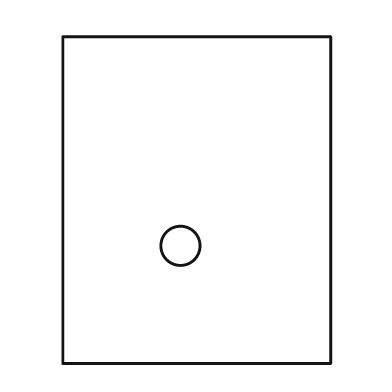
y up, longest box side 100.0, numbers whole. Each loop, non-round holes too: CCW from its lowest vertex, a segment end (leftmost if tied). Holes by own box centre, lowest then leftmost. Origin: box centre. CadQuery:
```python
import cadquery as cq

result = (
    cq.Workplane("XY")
    .moveTo(-41.0, -50.0)
    .lineTo(41.0, -50.0)
    .lineTo(41.0, 50.0)
    .lineTo(-41.0, 50.0)
    .close()
    .moveTo(-5.0, -14.0)
    .circle(6.0)
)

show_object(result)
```